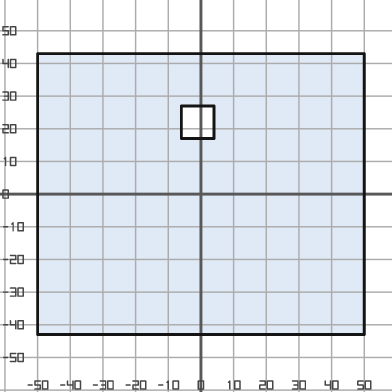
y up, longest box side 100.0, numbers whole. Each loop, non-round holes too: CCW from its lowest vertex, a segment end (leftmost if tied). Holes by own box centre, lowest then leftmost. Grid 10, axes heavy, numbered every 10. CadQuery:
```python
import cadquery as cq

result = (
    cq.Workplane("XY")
    .moveTo(-50.0, -43.0)
    .lineTo(50.0, -43.0)
    .lineTo(50.0, 43.0)
    .lineTo(-50.0, 43.0)
    .close()
    .moveTo(-6.0, 17.0)
    .lineTo(4.0, 17.0)
    .lineTo(4.0, 27.0)
    .lineTo(-6.0, 27.0)
    .close()
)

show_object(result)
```